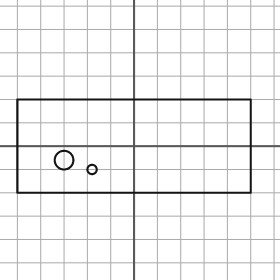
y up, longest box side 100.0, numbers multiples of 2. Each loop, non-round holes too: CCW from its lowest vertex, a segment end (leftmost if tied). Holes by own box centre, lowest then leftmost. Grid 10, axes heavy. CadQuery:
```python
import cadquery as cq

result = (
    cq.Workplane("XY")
    .moveTo(-50.0, -20.0)
    .lineTo(50.0, -20.0)
    .lineTo(50.0, 20.0)
    .lineTo(-50.0, 20.0)
    .close()
    .moveTo(-18.0, -10.0)
    .circle(2.0)
    .moveTo(-30.0, -6.0)
    .circle(4.0)
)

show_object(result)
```